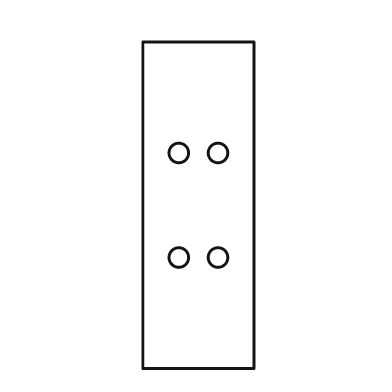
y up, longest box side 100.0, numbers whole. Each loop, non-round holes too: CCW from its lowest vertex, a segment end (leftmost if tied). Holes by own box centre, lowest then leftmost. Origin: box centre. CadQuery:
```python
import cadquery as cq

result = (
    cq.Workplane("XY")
    .moveTo(-17.0, -50.0)
    .lineTo(17.0, -50.0)
    .lineTo(17.0, 50.0)
    .lineTo(-17.0, 50.0)
    .close()
    .moveTo(-6.0, -16.0)
    .circle(3.0)
    .moveTo(6.0, -16.0)
    .circle(3.0)
    .moveTo(-6.0, 16.0)
    .circle(3.0)
    .moveTo(6.0, 16.0)
    .circle(3.0)
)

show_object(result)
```